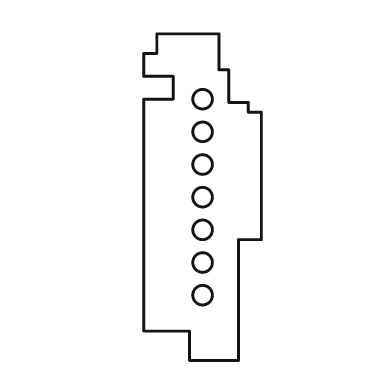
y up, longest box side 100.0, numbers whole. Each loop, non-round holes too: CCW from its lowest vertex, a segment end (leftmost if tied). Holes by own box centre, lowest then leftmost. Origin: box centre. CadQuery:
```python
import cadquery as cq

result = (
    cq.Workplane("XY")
    .moveTo(-4.0, -50.0)
    .lineTo(11.0, -50.0)
    .lineTo(11.0, -13.0)
    .lineTo(18.0, -13.0)
    .lineTo(18.0, 26.0)
    .lineTo(14.0, 26.0)
    .lineTo(14.0, 29.0)
    .lineTo(8.0, 29.0)
    .lineTo(8.0, 39.0)
    .lineTo(5.0, 39.0)
    .lineTo(5.0, 50.0)
    .lineTo(-14.0, 50.0)
    .lineTo(-14.0, 44.0)
    .lineTo(-18.0, 44.0)
    .lineTo(-18.0, 37.0)
    .lineTo(-9.0, 37.0)
    .lineTo(-9.0, 30.0)
    .lineTo(-18.0, 30.0)
    .lineTo(-18.0, -41.0)
    .lineTo(-4.0, -41.0)
    .close()
    .moveTo(0.0, -30.0)
    .circle(3.0)
    .moveTo(0.0, -20.0)
    .circle(3.0)
    .moveTo(0.0, -10.0)
    .circle(3.0)
    .moveTo(0.0, 0.0)
    .circle(3.0)
    .moveTo(0.0, 10.0)
    .circle(3.0)
    .moveTo(0.0, 20.0)
    .circle(3.0)
    .moveTo(0.0, 30.0)
    .circle(3.0)
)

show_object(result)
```